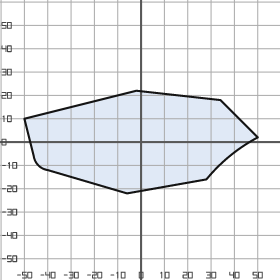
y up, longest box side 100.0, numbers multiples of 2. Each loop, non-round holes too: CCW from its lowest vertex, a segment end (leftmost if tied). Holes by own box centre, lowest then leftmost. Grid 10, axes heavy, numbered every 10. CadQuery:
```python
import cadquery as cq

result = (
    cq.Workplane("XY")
    .moveTo(-6.0, -22.0)
    .lineTo(28.0, -16.0)
    .threePointArc((38.0, -6.0), (50.0, 2.0))
    .lineTo(34.0, 18.0)
    .lineTo(-2.0, 22.0)
    .lineTo(-50.0, 10.0)
    .lineTo(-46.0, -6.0)
    .threePointArc((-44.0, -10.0), (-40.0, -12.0))
    .close()
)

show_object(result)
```